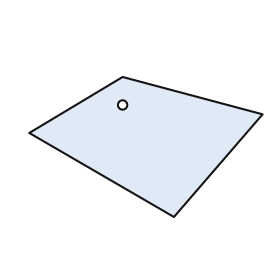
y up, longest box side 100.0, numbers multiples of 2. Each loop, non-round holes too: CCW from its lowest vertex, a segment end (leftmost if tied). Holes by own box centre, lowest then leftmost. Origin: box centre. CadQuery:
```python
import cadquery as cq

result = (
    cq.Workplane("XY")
    .moveTo(12.0, -30.0)
    .lineTo(50.0, 14.0)
    .lineTo(-10.0, 30.0)
    .lineTo(-50.0, 6.0)
    .close()
    .moveTo(-10.0, 18.0)
    .circle(2.0)
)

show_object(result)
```